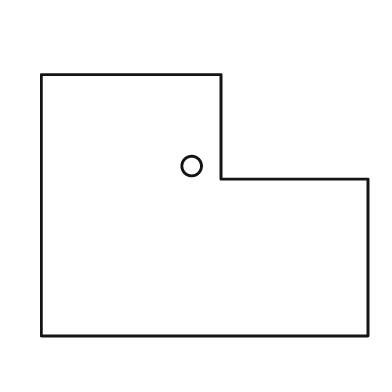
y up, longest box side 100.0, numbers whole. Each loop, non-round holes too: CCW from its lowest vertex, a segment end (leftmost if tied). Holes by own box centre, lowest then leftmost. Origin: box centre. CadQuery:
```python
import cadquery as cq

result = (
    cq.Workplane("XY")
    .moveTo(-50.0, -40.0)
    .lineTo(50.0, -40.0)
    .lineTo(50.0, 8.0)
    .lineTo(5.0, 8.0)
    .lineTo(5.0, 40.0)
    .lineTo(-50.0, 40.0)
    .close()
    .moveTo(-4.0, 12.0)
    .circle(3.0)
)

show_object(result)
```